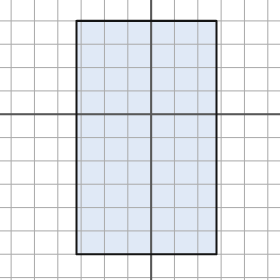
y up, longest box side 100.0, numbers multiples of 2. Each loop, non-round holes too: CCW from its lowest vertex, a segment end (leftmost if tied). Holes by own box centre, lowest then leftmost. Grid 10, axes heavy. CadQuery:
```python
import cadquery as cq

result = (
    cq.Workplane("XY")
    .moveTo(-32.0, -60.0)
    .lineTo(28.0, -60.0)
    .lineTo(28.0, 40.0)
    .lineTo(-32.0, 40.0)
    .close()
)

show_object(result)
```